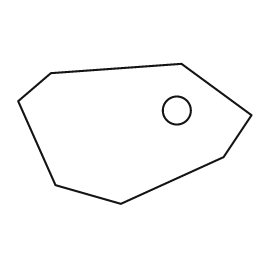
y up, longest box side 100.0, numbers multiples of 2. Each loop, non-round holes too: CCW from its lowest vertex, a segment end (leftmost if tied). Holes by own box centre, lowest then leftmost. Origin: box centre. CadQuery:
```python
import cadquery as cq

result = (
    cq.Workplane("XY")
    .moveTo(-6.0, -30.0)
    .lineTo(38.0, -10.0)
    .lineTo(50.0, 8.0)
    .lineTo(20.0, 30.0)
    .lineTo(-36.0, 26.0)
    .lineTo(-50.0, 14.0)
    .lineTo(-34.0, -22.0)
    .close()
    .moveTo(18.0, 10.0)
    .circle(6.0)
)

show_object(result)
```